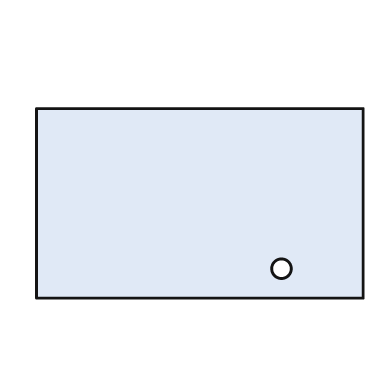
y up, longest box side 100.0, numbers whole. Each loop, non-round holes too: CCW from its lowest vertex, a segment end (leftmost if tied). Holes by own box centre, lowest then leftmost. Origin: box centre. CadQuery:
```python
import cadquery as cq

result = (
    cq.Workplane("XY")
    .moveTo(-50.0, -29.0)
    .lineTo(50.0, -29.0)
    .lineTo(50.0, 29.0)
    .lineTo(-50.0, 29.0)
    .close()
    .moveTo(25.0, -20.0)
    .circle(3.0)
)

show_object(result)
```